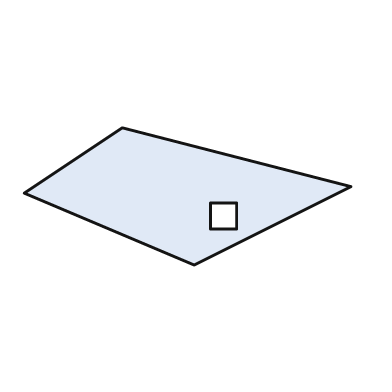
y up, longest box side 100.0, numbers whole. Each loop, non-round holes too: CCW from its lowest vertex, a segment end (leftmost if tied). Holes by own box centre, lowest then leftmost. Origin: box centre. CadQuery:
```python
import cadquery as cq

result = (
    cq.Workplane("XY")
    .moveTo(2.0, -21.0)
    .lineTo(50.0, 3.0)
    .lineTo(-20.0, 21.0)
    .lineTo(-50.0, 1.0)
    .close()
    .moveTo(7.0, -10.0)
    .lineTo(15.0, -10.0)
    .lineTo(15.0, -2.0)
    .lineTo(7.0, -2.0)
    .close()
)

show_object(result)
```